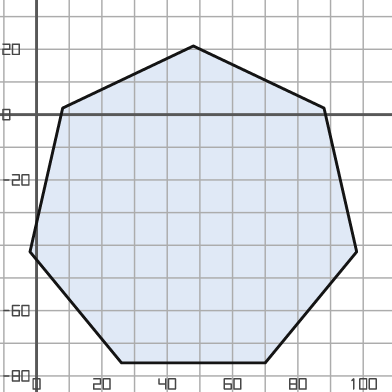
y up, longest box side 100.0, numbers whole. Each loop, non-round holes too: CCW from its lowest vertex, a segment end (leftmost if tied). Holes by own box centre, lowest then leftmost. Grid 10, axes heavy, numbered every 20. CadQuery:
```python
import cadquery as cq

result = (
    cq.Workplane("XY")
    .moveTo(26.0, -76.0)
    .lineTo(70.0, -76.0)
    .lineTo(98.0, -42.0)
    .lineTo(88.0, 2.0)
    .lineTo(48.0, 21.0)
    .lineTo(8.0, 2.0)
    .lineTo(-2.0, -42.0)
    .close()
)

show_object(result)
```